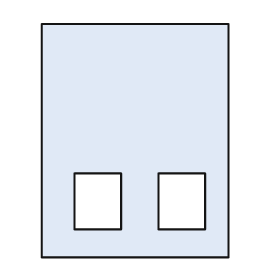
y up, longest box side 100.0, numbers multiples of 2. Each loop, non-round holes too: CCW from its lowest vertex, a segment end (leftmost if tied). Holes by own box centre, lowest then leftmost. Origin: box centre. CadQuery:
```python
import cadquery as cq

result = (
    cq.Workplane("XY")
    .moveTo(-40.0, -50.0)
    .lineTo(40.0, -50.0)
    .lineTo(40.0, 50.0)
    .lineTo(-40.0, 50.0)
    .close()
    .moveTo(-26.0, -38.0)
    .lineTo(-6.0, -38.0)
    .lineTo(-6.0, -14.0)
    .lineTo(-26.0, -14.0)
    .close()
    .moveTo(10.0, -38.0)
    .lineTo(30.0, -38.0)
    .lineTo(30.0, -14.0)
    .lineTo(10.0, -14.0)
    .close()
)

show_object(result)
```